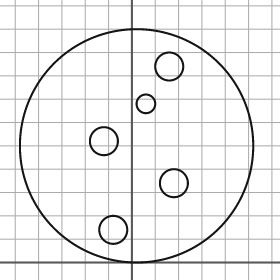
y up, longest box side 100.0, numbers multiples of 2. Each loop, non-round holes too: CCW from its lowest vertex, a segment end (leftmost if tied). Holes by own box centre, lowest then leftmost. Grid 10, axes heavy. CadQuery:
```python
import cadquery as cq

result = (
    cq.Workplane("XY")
    .moveTo(2.0, 50.0)
    .circle(50.0)
    .moveTo(-8.0, 14.0)
    .circle(6.0)
    .moveTo(18.0, 34.0)
    .circle(6.0)
    .moveTo(-12.0, 52.0)
    .circle(6.0)
    .moveTo(6.0, 68.0)
    .circle(4.0)
    .moveTo(16.0, 84.0)
    .circle(6.0)
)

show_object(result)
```